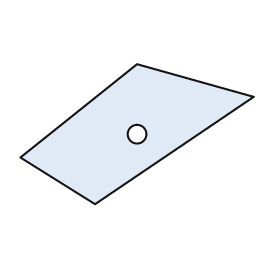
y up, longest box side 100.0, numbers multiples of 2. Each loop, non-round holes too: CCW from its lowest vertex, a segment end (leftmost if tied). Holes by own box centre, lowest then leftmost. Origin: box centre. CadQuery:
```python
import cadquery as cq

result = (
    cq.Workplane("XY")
    .moveTo(-18.0, -30.0)
    .lineTo(50.0, 16.0)
    .lineTo(0.0, 30.0)
    .lineTo(-50.0, -10.0)
    .close()
    .moveTo(0.0, 0.0)
    .circle(4.0)
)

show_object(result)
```